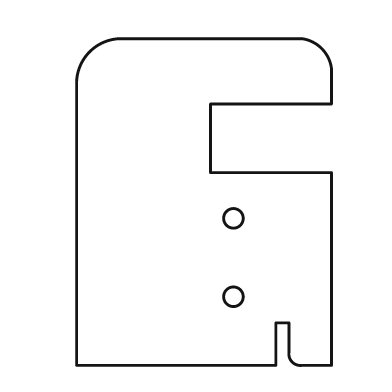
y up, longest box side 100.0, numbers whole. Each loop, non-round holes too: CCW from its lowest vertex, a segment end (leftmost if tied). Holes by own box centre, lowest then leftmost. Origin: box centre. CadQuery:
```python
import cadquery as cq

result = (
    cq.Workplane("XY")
    .moveTo(-39.0, -50.0)
    .lineTo(22.0, -50.0)
    .lineTo(22.0, -37.0)
    .lineTo(26.0, -37.0)
    .lineTo(26.0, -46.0)
    .threePointArc((27.0, -49.0), (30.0, -50.0))
    .lineTo(39.0, -50.0)
    .lineTo(39.0, 9.0)
    .lineTo(2.0, 9.0)
    .lineTo(2.0, 30.0)
    .lineTo(39.0, 30.0)
    .lineTo(39.0, 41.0)
    .threePointArc((36.0, 47.0), (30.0, 50.0))
    .lineTo(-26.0, 50.0)
    .threePointArc((-35.0, 46.0), (-39.0, 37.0))
    .close()
    .moveTo(9.0, -29.0)
    .circle(3.0)
    .moveTo(9.0, -5.0)
    .circle(3.0)
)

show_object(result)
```